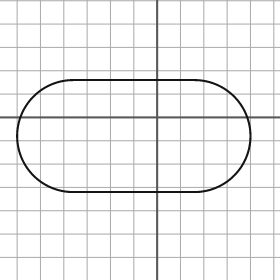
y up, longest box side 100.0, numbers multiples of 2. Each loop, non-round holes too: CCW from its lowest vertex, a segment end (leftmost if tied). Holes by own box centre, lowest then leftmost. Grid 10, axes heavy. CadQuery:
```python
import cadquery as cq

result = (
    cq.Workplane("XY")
    .moveTo(-36.0, -32.0)
    .lineTo(16.0, -32.0)
    .threePointArc((40.0, -8.0), (16.0, 16.0))
    .lineTo(-36.0, 16.0)
    .threePointArc((-60.0, -8.0), (-36.0, -32.0))
    .close()
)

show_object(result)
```